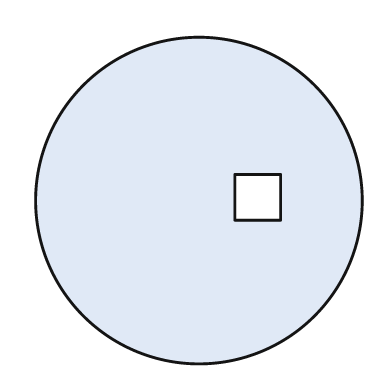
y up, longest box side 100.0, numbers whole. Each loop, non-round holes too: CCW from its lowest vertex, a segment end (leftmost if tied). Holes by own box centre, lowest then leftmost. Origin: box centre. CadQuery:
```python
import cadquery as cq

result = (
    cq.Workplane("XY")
    .moveTo(0.0, 0.0)
    .circle(50.0)
    .moveTo(11.0, -6.0)
    .lineTo(25.0, -6.0)
    .lineTo(25.0, 8.0)
    .lineTo(11.0, 8.0)
    .close()
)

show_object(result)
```